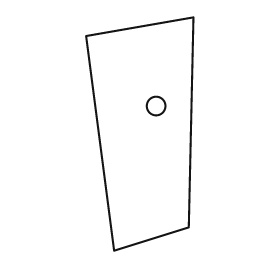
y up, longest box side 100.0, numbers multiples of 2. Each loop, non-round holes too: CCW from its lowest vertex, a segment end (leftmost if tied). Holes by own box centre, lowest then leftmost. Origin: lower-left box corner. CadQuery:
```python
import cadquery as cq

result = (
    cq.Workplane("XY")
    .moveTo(12.0, 0.0)
    .lineTo(44.0, 10.0)
    .lineTo(46.0, 100.0)
    .lineTo(0.0, 92.0)
    .close()
    .moveTo(30.0, 62.0)
    .circle(4.0)
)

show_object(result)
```